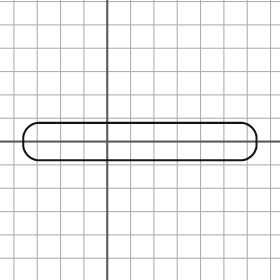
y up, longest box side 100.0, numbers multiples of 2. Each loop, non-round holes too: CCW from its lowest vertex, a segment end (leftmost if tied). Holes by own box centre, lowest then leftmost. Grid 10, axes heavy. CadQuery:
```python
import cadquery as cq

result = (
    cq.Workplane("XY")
    .moveTo(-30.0, -8.0)
    .lineTo(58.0, -8.0)
    .threePointArc((62.0, -6.0), (64.0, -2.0))
    .lineTo(64.0, 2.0)
    .threePointArc((62.0, 6.0), (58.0, 8.0))
    .lineTo(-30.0, 8.0)
    .threePointArc((-34.0, 6.0), (-36.0, 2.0))
    .lineTo(-36.0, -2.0)
    .threePointArc((-34.0, -6.0), (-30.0, -8.0))
    .close()
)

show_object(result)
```